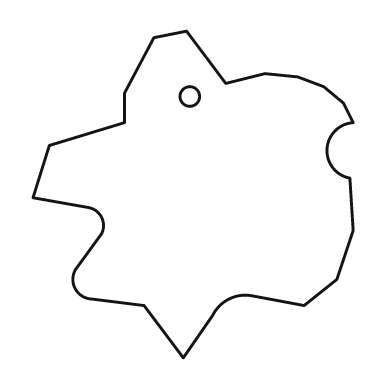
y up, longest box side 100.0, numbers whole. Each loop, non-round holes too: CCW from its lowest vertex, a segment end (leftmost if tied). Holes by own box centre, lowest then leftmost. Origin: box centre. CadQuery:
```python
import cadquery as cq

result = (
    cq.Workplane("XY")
    .moveTo(-3.0, -50.0)
    .lineTo(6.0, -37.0)
    .threePointArc((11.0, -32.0), (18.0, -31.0))
    .lineTo(34.0, -34.0)
    .lineTo(44.0, -26.0)
    .lineTo(49.0, -11.0)
    .lineTo(48.0, 5.0)
    .threePointArc((41.0, 14.0), (49.0, 22.0))
    .lineTo(46.0, 28.0)
    .lineTo(40.0, 33.0)
    .lineTo(32.0, 36.0)
    .lineTo(22.0, 37.0)
    .lineTo(10.0, 34.0)
    .lineTo(-2.0, 50.0)
    .lineTo(-12.0, 48.0)
    .lineTo(-21.0, 31.0)
    .lineTo(-21.0, 22.0)
    .lineTo(-44.0, 15.0)
    .lineTo(-49.0, -1.0)
    .lineTo(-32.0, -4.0)
    .threePointArc((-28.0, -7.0), (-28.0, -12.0))
    .lineTo(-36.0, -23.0)
    .threePointArc((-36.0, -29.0), (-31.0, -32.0))
    .lineTo(-15.0, -34.0)
    .close()
    .moveTo(-1.0, 30.0)
    .circle(3.0)
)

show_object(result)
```